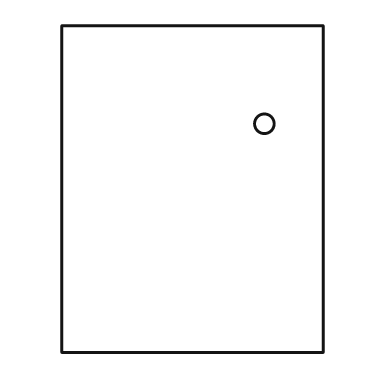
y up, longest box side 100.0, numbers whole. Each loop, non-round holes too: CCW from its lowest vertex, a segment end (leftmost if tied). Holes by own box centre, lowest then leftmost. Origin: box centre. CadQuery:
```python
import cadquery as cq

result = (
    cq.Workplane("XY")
    .moveTo(-40.0, -50.0)
    .lineTo(40.0, -50.0)
    .lineTo(40.0, 50.0)
    .lineTo(-40.0, 50.0)
    .close()
    .moveTo(22.0, 20.0)
    .circle(3.0)
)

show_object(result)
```